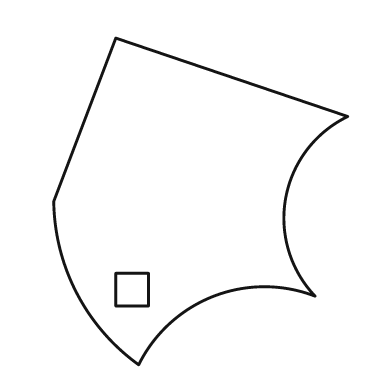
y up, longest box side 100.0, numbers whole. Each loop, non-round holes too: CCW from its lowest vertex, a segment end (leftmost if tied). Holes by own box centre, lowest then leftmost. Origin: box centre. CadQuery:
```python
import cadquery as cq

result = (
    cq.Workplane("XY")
    .moveTo(-19.0, -50.0)
    .threePointArc((4.0, -29.0), (35.0, -29.0))
    .threePointArc((26.0, 1.0), (45.0, 26.0))
    .lineTo(-26.0, 50.0)
    .lineTo(-45.0, 0.0)
    .threePointArc((-38.0, -28.0), (-19.0, -50.0))
    .close()
    .moveTo(-26.0, -32.0)
    .lineTo(-16.0, -32.0)
    .lineTo(-16.0, -22.0)
    .lineTo(-26.0, -22.0)
    .close()
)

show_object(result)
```